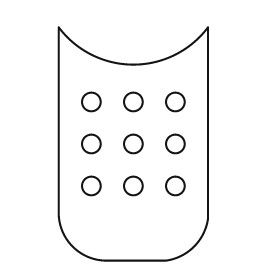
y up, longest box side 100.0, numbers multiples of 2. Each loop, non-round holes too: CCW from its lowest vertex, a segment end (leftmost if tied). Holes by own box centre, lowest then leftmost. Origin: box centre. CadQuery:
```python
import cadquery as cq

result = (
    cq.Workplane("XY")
    .moveTo(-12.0, -50.0)
    .lineTo(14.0, -50.0)
    .threePointArc((26.0, -44.0), (32.0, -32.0))
    .lineTo(32.0, 50.0)
    .threePointArc((0.0, 34.0), (-32.0, 50.0))
    .lineTo(-32.0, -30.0)
    .threePointArc((-26.0, -44.0), (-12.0, -50.0))
    .close()
    .moveTo(-18.0, -18.0)
    .circle(4.0)
    .moveTo(0.0, -18.0)
    .circle(4.0)
    .moveTo(18.0, -18.0)
    .circle(4.0)
    .moveTo(-18.0, 0.0)
    .circle(4.0)
    .moveTo(0.0, 0.0)
    .circle(4.0)
    .moveTo(18.0, 0.0)
    .circle(4.0)
    .moveTo(-18.0, 18.0)
    .circle(4.0)
    .moveTo(0.0, 18.0)
    .circle(4.0)
    .moveTo(18.0, 18.0)
    .circle(4.0)
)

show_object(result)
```